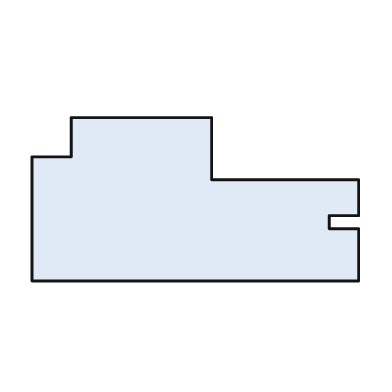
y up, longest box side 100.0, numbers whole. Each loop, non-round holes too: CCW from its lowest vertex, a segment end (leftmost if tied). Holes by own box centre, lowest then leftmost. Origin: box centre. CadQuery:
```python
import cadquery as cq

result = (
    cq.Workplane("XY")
    .moveTo(-50.0, -25.0)
    .lineTo(50.0, -25.0)
    .lineTo(50.0, -9.0)
    .lineTo(41.0, -9.0)
    .lineTo(41.0, -5.0)
    .lineTo(50.0, -5.0)
    .lineTo(50.0, 6.0)
    .lineTo(5.0, 6.0)
    .lineTo(5.0, 25.0)
    .lineTo(-38.0, 25.0)
    .lineTo(-38.0, 13.0)
    .lineTo(-50.0, 13.0)
    .close()
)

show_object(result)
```